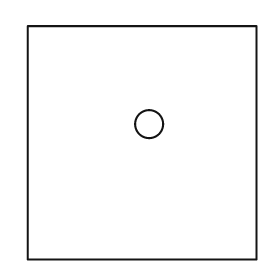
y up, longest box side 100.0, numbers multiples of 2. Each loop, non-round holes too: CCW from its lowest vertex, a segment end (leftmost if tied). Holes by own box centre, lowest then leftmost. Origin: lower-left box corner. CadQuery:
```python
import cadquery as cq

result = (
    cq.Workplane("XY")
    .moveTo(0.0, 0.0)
    .lineTo(98.0, 0.0)
    .lineTo(98.0, 100.0)
    .lineTo(0.0, 100.0)
    .close()
    .moveTo(52.0, 58.0)
    .circle(6.0)
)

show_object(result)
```